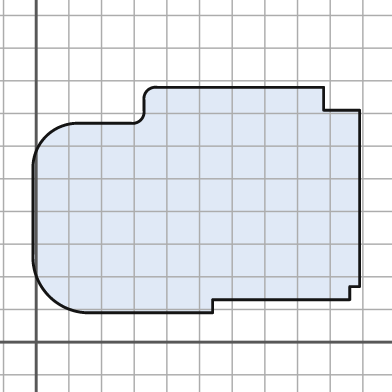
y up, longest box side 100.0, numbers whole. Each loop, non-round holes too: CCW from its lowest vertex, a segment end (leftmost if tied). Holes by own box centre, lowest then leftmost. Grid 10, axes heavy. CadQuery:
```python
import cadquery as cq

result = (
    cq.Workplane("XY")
    .moveTo(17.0, 9.0)
    .lineTo(54.0, 9.0)
    .lineTo(54.0, 13.0)
    .lineTo(96.0, 13.0)
    .lineTo(96.0, 17.0)
    .lineTo(99.0, 17.0)
    .lineTo(99.0, 71.0)
    .lineTo(88.0, 71.0)
    .lineTo(88.0, 78.0)
    .lineTo(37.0, 78.0)
    .threePointArc((34.0, 77.0), (33.0, 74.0))
    .lineTo(33.0, 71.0)
    .threePointArc((32.0, 68.0), (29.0, 67.0))
    .lineTo(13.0, 67.0)
    .threePointArc((3.0, 63.0), (-1.0, 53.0))
    .lineTo(-1.0, 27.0)
    .threePointArc((4.0, 14.0), (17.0, 9.0))
    .close()
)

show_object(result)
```